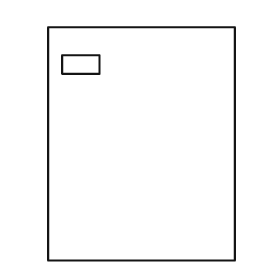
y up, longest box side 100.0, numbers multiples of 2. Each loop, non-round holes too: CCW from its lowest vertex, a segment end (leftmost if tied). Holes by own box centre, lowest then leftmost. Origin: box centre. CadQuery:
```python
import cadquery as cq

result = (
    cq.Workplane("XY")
    .moveTo(-40.0, -50.0)
    .lineTo(40.0, -50.0)
    .lineTo(40.0, 50.0)
    .lineTo(-40.0, 50.0)
    .close()
    .moveTo(-34.0, 30.0)
    .lineTo(-18.0, 30.0)
    .lineTo(-18.0, 38.0)
    .lineTo(-34.0, 38.0)
    .close()
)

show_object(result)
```